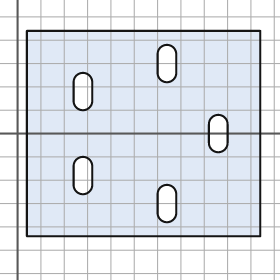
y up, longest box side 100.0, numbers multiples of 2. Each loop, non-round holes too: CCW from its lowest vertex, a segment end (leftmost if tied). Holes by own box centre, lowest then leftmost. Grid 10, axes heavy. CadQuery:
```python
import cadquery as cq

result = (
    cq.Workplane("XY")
    .moveTo(4.0, -44.0)
    .lineTo(104.0, -44.0)
    .lineTo(104.0, 44.0)
    .lineTo(4.0, 44.0)
    .close()
    .moveTo(60.0, -34.0)
    .threePointArc((64.0, -38.0), (68.0, -34.0))
    .lineTo(68.0, -26.0)
    .threePointArc((64.0, -22.0), (60.0, -26.0))
    .close()
    .moveTo(24.0, -22.0)
    .threePointArc((28.0, -26.0), (32.0, -22.0))
    .lineTo(32.0, -14.0)
    .threePointArc((28.0, -10.0), (24.0, -14.0))
    .close()
    .moveTo(82.0, -4.0)
    .threePointArc((86.0, -8.0), (90.0, -4.0))
    .lineTo(90.0, 4.0)
    .threePointArc((86.0, 8.0), (82.0, 4.0))
    .close()
    .moveTo(24.0, 14.0)
    .threePointArc((28.0, 10.0), (32.0, 14.0))
    .lineTo(32.0, 22.0)
    .threePointArc((28.0, 26.0), (24.0, 22.0))
    .close()
    .moveTo(60.0, 26.0)
    .threePointArc((64.0, 22.0), (68.0, 26.0))
    .lineTo(68.0, 34.0)
    .threePointArc((64.0, 38.0), (60.0, 34.0))
    .close()
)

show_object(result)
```